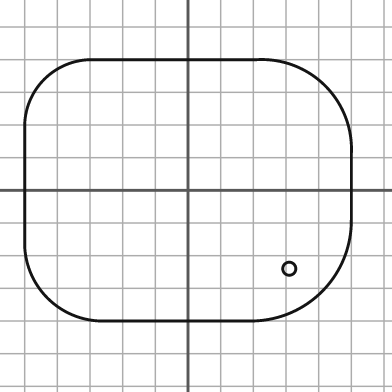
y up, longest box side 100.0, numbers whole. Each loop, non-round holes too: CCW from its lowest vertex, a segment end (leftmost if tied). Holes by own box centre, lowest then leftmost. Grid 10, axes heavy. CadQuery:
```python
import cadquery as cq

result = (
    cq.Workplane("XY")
    .moveTo(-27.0, -40.0)
    .lineTo(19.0, -40.0)
    .threePointArc((41.0, -31.0), (50.0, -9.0))
    .lineTo(50.0, 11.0)
    .threePointArc((42.0, 32.0), (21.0, 40.0))
    .lineTo(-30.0, 40.0)
    .threePointArc((-44.0, 34.0), (-50.0, 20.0))
    .lineTo(-50.0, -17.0)
    .threePointArc((-43.0, -33.0), (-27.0, -40.0))
    .close()
    .moveTo(31.0, -24.0)
    .circle(2.0)
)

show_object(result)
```